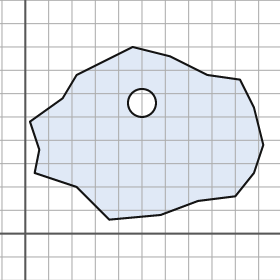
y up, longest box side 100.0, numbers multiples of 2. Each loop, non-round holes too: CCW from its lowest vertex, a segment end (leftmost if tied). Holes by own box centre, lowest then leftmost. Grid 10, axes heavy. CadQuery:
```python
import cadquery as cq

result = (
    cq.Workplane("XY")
    .moveTo(36.0, 6.0)
    .lineTo(58.0, 8.0)
    .lineTo(74.0, 14.0)
    .lineTo(90.0, 16.0)
    .lineTo(98.0, 26.0)
    .lineTo(102.0, 38.0)
    .lineTo(98.0, 54.0)
    .lineTo(92.0, 66.0)
    .lineTo(78.0, 68.0)
    .lineTo(62.0, 76.0)
    .lineTo(46.0, 80.0)
    .lineTo(22.0, 68.0)
    .lineTo(16.0, 58.0)
    .lineTo(2.0, 48.0)
    .lineTo(6.0, 36.0)
    .lineTo(4.0, 26.0)
    .lineTo(22.0, 20.0)
    .close()
    .moveTo(50.0, 56.0)
    .circle(6.0)
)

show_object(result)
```